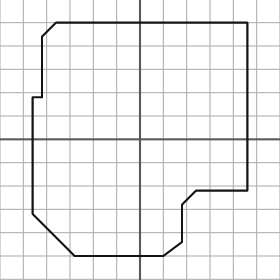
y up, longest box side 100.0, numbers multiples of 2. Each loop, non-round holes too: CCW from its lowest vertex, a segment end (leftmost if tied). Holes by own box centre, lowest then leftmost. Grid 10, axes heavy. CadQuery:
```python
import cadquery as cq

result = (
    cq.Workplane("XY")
    .moveTo(-28.0, -50.0)
    .lineTo(10.0, -50.0)
    .lineTo(18.0, -44.0)
    .lineTo(18.0, -28.0)
    .lineTo(24.0, -22.0)
    .lineTo(46.0, -22.0)
    .lineTo(46.0, 50.0)
    .lineTo(-36.0, 50.0)
    .lineTo(-42.0, 44.0)
    .lineTo(-42.0, 18.0)
    .lineTo(-46.0, 18.0)
    .lineTo(-46.0, -32.0)
    .close()
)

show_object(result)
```